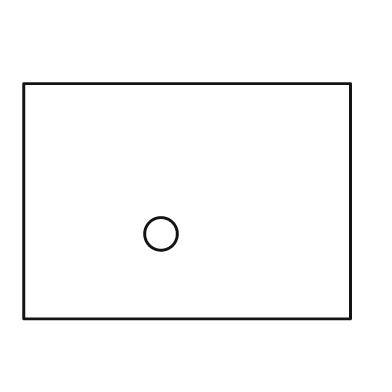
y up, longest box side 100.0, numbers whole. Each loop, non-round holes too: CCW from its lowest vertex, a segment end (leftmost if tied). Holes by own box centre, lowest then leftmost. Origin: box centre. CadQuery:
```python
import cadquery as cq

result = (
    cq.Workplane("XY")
    .moveTo(-50.0, -36.0)
    .lineTo(50.0, -36.0)
    .lineTo(50.0, 36.0)
    .lineTo(-50.0, 36.0)
    .close()
    .moveTo(-8.0, -10.0)
    .circle(5.0)
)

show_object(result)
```